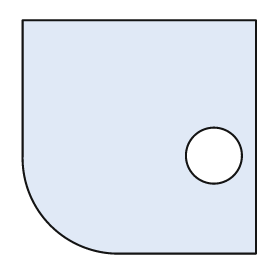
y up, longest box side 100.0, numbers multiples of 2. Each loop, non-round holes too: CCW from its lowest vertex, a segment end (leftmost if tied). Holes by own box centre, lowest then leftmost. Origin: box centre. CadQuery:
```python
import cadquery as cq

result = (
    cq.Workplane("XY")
    .moveTo(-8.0, -50.0)
    .lineTo(50.0, -50.0)
    .lineTo(50.0, 50.0)
    .lineTo(-50.0, 50.0)
    .lineTo(-50.0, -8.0)
    .threePointArc((-38.0, -38.0), (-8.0, -50.0))
    .close()
    .moveTo(32.0, -8.0)
    .circle(12.0)
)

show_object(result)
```